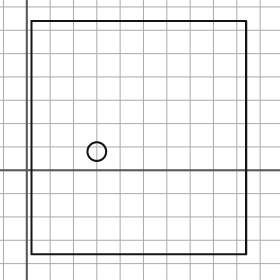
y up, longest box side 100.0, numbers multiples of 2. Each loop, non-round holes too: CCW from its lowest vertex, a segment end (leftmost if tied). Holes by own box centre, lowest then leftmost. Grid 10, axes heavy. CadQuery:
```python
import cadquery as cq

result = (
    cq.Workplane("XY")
    .moveTo(2.0, -36.0)
    .lineTo(94.0, -36.0)
    .lineTo(94.0, 64.0)
    .lineTo(2.0, 64.0)
    .close()
    .moveTo(30.0, 8.0)
    .circle(4.0)
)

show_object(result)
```